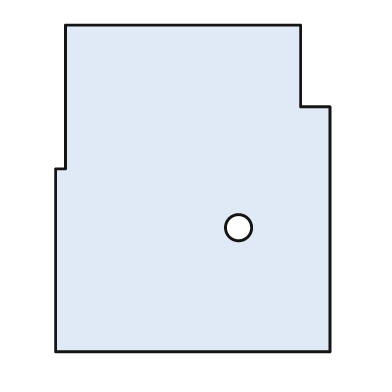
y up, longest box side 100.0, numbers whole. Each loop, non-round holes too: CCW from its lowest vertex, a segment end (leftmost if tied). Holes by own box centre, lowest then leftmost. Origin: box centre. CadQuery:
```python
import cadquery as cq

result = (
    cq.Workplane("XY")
    .moveTo(-42.0, -50.0)
    .lineTo(42.0, -50.0)
    .lineTo(42.0, 25.0)
    .lineTo(33.0, 25.0)
    .lineTo(33.0, 50.0)
    .lineTo(-39.0, 50.0)
    .lineTo(-39.0, 6.0)
    .lineTo(-42.0, 6.0)
    .close()
    .moveTo(14.0, -12.0)
    .circle(4.0)
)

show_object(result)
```